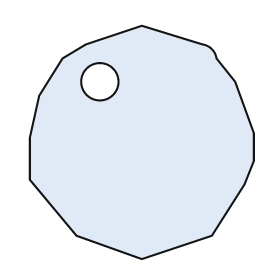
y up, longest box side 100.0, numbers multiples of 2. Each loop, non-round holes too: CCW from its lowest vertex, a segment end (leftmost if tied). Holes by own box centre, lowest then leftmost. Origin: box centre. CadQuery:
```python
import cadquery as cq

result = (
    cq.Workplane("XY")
    .moveTo(0.0, -50.0)
    .lineTo(30.0, -40.0)
    .lineTo(44.0, -18.0)
    .lineTo(48.0, -8.0)
    .lineTo(48.0, 4.0)
    .lineTo(40.0, 26.0)
    .lineTo(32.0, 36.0)
    .threePointArc((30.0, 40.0), (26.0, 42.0))
    .lineTo(0.0, 50.0)
    .lineTo(-24.0, 42.0)
    .lineTo(-34.0, 36.0)
    .lineTo(-44.0, 20.0)
    .lineTo(-48.0, 2.0)
    .lineTo(-48.0, -16.0)
    .lineTo(-28.0, -40.0)
    .close()
    .moveTo(-18.0, 26.0)
    .circle(8.0)
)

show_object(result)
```